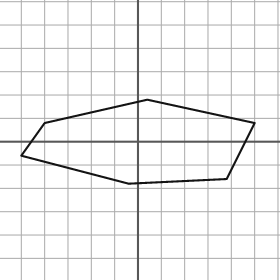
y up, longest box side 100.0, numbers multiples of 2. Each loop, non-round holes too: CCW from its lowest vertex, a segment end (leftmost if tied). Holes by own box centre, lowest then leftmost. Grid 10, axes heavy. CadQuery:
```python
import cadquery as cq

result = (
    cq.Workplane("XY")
    .moveTo(-4.0, -18.0)
    .lineTo(38.0, -16.0)
    .lineTo(50.0, 8.0)
    .lineTo(4.0, 18.0)
    .lineTo(-40.0, 8.0)
    .lineTo(-50.0, -6.0)
    .close()
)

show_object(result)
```